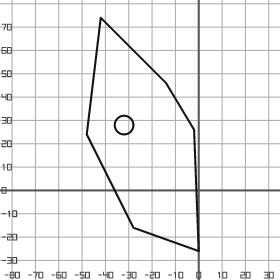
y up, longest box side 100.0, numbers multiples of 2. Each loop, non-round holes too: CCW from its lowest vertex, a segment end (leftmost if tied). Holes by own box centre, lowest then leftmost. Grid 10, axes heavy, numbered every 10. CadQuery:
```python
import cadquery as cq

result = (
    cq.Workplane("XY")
    .moveTo(0.0, -26.0)
    .lineTo(-2.0, 26.0)
    .lineTo(-14.0, 46.0)
    .lineTo(-42.0, 74.0)
    .lineTo(-48.0, 24.0)
    .lineTo(-28.0, -16.0)
    .close()
    .moveTo(-32.0, 28.0)
    .circle(4.0)
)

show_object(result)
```